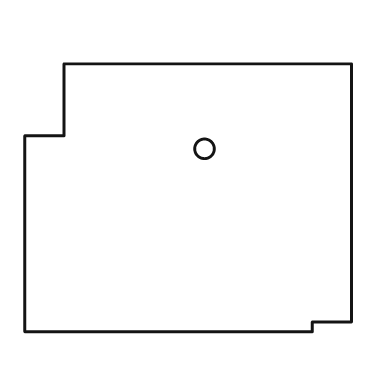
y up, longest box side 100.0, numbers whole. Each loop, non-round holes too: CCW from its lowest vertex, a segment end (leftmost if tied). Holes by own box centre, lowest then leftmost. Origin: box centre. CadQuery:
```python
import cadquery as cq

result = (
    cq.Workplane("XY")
    .moveTo(-50.0, -41.0)
    .lineTo(38.0, -41.0)
    .lineTo(38.0, -38.0)
    .lineTo(50.0, -38.0)
    .lineTo(50.0, 41.0)
    .lineTo(-38.0, 41.0)
    .lineTo(-38.0, 19.0)
    .lineTo(-50.0, 19.0)
    .close()
    .moveTo(5.0, 15.0)
    .circle(3.0)
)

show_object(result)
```